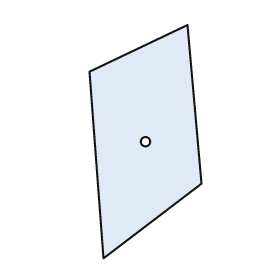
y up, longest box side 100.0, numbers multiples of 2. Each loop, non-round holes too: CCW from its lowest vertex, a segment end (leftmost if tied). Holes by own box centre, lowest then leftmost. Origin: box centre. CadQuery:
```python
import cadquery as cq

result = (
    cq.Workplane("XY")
    .moveTo(-18.0, -50.0)
    .lineTo(24.0, -18.0)
    .lineTo(18.0, 50.0)
    .lineTo(-24.0, 30.0)
    .close()
    .moveTo(0.0, 0.0)
    .circle(2.0)
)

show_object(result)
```